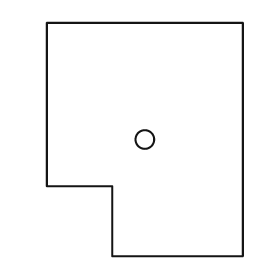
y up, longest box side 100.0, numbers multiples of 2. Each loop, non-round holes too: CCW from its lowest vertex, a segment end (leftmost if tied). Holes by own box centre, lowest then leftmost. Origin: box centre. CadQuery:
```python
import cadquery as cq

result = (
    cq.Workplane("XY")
    .moveTo(-14.0, -50.0)
    .lineTo(42.0, -50.0)
    .lineTo(42.0, 50.0)
    .lineTo(-42.0, 50.0)
    .lineTo(-42.0, -20.0)
    .lineTo(-14.0, -20.0)
    .close()
    .moveTo(0.0, 0.0)
    .circle(4.0)
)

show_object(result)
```